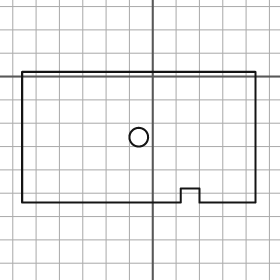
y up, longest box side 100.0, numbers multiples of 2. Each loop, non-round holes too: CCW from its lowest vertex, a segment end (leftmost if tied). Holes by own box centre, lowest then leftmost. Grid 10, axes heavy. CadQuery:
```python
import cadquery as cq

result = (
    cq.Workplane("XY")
    .moveTo(-56.0, -54.0)
    .lineTo(12.0, -54.0)
    .lineTo(12.0, -48.0)
    .lineTo(20.0, -48.0)
    .lineTo(20.0, -54.0)
    .lineTo(44.0, -54.0)
    .lineTo(44.0, 2.0)
    .lineTo(-56.0, 2.0)
    .close()
    .moveTo(-6.0, -26.0)
    .circle(4.0)
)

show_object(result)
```